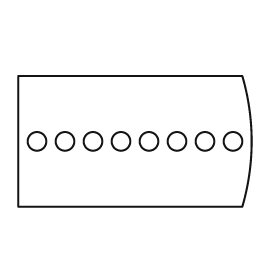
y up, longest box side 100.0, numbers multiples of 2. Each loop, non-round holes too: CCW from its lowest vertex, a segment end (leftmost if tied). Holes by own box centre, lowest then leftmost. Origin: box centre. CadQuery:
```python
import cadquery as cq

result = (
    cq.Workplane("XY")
    .moveTo(-50.0, -28.0)
    .lineTo(46.0, -28.0)
    .threePointArc((50.0, 0.0), (46.0, 28.0))
    .lineTo(-50.0, 28.0)
    .close()
    .moveTo(-42.0, 0.0)
    .circle(4.0)
    .moveTo(-30.0, 0.0)
    .circle(4.0)
    .moveTo(-18.0, 0.0)
    .circle(4.0)
    .moveTo(-6.0, 0.0)
    .circle(4.0)
    .moveTo(6.0, 0.0)
    .circle(4.0)
    .moveTo(18.0, 0.0)
    .circle(4.0)
    .moveTo(30.0, 0.0)
    .circle(4.0)
    .moveTo(42.0, 0.0)
    .circle(4.0)
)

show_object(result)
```